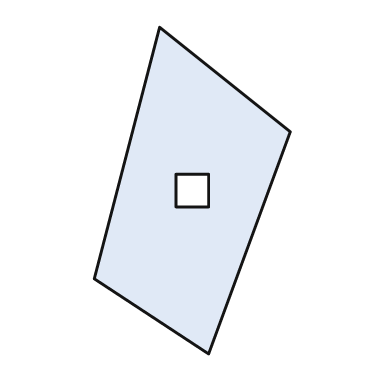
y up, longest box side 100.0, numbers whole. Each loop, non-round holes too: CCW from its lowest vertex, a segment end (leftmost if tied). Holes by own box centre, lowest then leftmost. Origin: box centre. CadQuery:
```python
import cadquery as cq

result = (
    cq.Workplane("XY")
    .moveTo(5.0, -50.0)
    .lineTo(30.0, 18.0)
    .lineTo(-10.0, 50.0)
    .lineTo(-30.0, -27.0)
    .close()
    .moveTo(-5.0, -5.0)
    .lineTo(5.0, -5.0)
    .lineTo(5.0, 5.0)
    .lineTo(-5.0, 5.0)
    .close()
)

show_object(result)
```